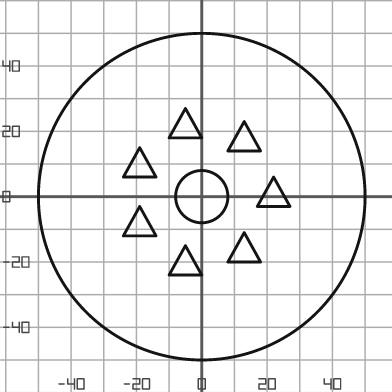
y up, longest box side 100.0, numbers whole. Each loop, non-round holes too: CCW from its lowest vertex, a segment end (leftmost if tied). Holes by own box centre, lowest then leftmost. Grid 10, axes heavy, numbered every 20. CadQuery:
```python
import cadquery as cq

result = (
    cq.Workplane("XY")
    .moveTo(0.0, 0.0)
    .circle(50.0)
    .moveTo(-10.0, -24.0)
    .lineTo(0.0, -24.0)
    .lineTo(-5.0, -15.0)
    .close()
    .moveTo(8.0, -20.0)
    .lineTo(18.0, -20.0)
    .lineTo(13.0, -11.0)
    .close()
    .moveTo(-24.0, -12.0)
    .lineTo(-14.0, -12.0)
    .lineTo(-19.0, -3.0)
    .close()
    .moveTo(0.0, 0.0)
    .circle(8.0)
    .moveTo(17.0, -3.0)
    .lineTo(27.0, -3.0)
    .lineTo(22.0, 6.0)
    .close()
    .moveTo(-24.0, 6.0)
    .lineTo(-14.0, 6.0)
    .lineTo(-19.0, 15.0)
    .close()
    .moveTo(8.0, 14.0)
    .lineTo(18.0, 14.0)
    .lineTo(13.0, 23.0)
    .close()
    .moveTo(-10.0, 18.0)
    .lineTo(0.0, 18.0)
    .lineTo(-5.0, 27.0)
    .close()
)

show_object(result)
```